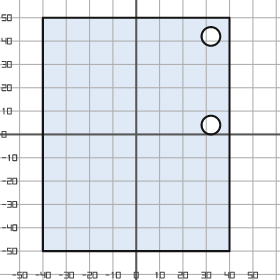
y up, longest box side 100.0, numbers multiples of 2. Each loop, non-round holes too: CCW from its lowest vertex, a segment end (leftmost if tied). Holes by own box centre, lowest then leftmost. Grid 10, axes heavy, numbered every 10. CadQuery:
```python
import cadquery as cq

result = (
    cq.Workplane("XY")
    .moveTo(-40.0, -50.0)
    .lineTo(40.0, -50.0)
    .lineTo(40.0, 50.0)
    .lineTo(-40.0, 50.0)
    .close()
    .moveTo(32.0, 4.0)
    .circle(4.0)
    .moveTo(32.0, 42.0)
    .circle(4.0)
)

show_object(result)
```